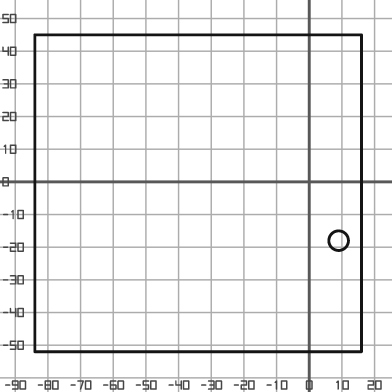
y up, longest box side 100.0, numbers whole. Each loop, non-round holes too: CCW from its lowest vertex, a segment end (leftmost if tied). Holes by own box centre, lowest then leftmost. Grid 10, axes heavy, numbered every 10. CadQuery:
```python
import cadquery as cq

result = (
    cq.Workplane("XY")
    .moveTo(-84.0, -52.0)
    .lineTo(16.0, -52.0)
    .lineTo(16.0, 45.0)
    .lineTo(-84.0, 45.0)
    .close()
    .moveTo(9.0, -18.0)
    .circle(3.0)
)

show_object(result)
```